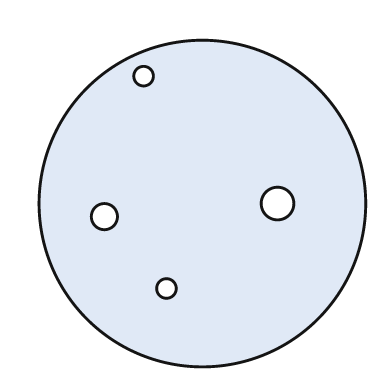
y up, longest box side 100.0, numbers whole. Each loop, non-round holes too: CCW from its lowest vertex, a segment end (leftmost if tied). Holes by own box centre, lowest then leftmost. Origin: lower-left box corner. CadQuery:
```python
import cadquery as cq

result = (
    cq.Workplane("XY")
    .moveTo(50.0, 50.0)
    .circle(50.0)
    .moveTo(39.0, 24.0)
    .circle(3.0)
    .moveTo(20.0, 46.0)
    .circle(4.0)
    .moveTo(73.0, 50.0)
    .circle(5.0)
    .moveTo(32.0, 89.0)
    .circle(3.0)
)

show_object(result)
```